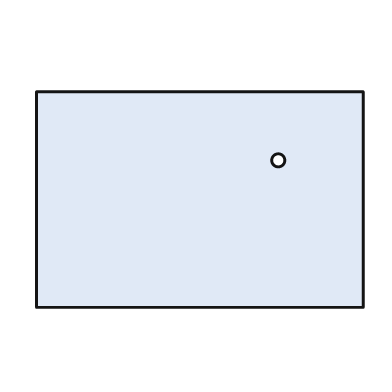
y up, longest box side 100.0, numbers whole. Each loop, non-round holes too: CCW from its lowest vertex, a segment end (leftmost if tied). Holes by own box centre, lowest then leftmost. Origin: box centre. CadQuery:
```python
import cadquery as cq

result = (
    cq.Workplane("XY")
    .moveTo(-50.0, -33.0)
    .lineTo(50.0, -33.0)
    .lineTo(50.0, 33.0)
    .lineTo(-50.0, 33.0)
    .close()
    .moveTo(24.0, 12.0)
    .circle(2.0)
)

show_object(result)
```